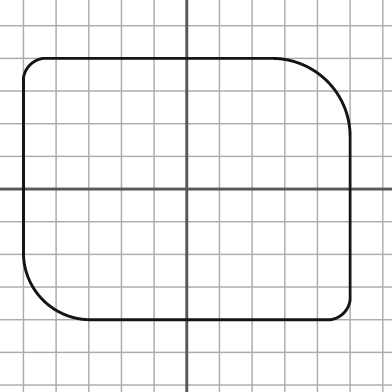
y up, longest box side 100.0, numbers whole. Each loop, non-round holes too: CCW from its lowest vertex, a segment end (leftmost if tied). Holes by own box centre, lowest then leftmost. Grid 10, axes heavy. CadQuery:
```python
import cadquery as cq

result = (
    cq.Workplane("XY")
    .moveTo(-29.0, -40.0)
    .lineTo(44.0, -40.0)
    .threePointArc((48.0, -38.0), (50.0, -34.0))
    .lineTo(50.0, 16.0)
    .threePointArc((43.0, 33.0), (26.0, 40.0))
    .lineTo(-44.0, 40.0)
    .threePointArc((-48.0, 38.0), (-50.0, 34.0))
    .lineTo(-50.0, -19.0)
    .threePointArc((-44.0, -34.0), (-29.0, -40.0))
    .close()
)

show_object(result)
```